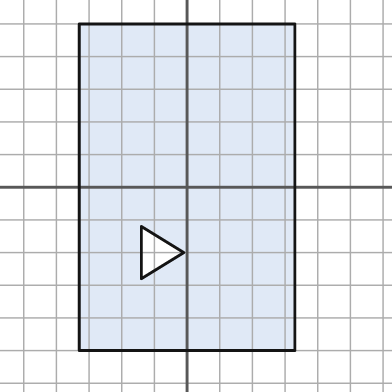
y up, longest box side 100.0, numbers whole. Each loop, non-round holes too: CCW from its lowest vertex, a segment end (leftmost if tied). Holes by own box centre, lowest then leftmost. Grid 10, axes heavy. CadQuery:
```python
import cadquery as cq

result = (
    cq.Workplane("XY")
    .moveTo(-33.0, -50.0)
    .lineTo(33.0, -50.0)
    .lineTo(33.0, 50.0)
    .lineTo(-33.0, 50.0)
    .close()
    .moveTo(-14.0, -28.0)
    .lineTo(-1.0, -20.0)
    .lineTo(-14.0, -12.0)
    .close()
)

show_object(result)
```